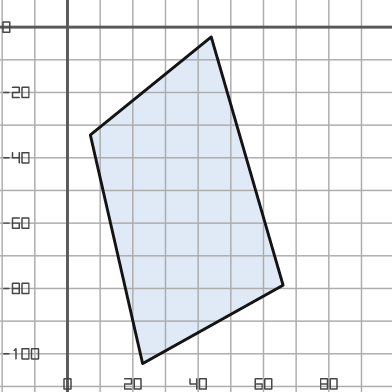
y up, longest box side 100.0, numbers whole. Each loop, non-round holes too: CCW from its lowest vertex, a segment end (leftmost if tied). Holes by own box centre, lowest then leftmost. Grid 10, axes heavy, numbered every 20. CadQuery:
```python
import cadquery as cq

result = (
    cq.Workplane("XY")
    .moveTo(23.0, -103.0)
    .lineTo(66.0, -79.0)
    .lineTo(44.0, -3.0)
    .lineTo(7.0, -33.0)
    .close()
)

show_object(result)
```